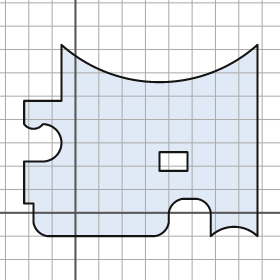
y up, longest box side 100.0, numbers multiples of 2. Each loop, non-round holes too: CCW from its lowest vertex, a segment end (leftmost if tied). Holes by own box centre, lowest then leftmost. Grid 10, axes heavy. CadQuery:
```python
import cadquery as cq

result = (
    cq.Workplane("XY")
    .moveTo(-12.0, -10.0)
    .lineTo(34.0, -10.0)
    .threePointArc((38.0, -8.0), (40.0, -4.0))
    .lineTo(40.0, 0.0)
    .threePointArc((42.0, 4.0), (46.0, 6.0))
    .lineTo(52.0, 6.0)
    .threePointArc((56.0, 4.0), (58.0, 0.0))
    .lineTo(58.0, -10.0)
    .threePointArc((68.0, -6.0), (78.0, -10.0))
    .lineTo(78.0, 72.0)
    .threePointArc((36.0, 56.0), (-6.0, 72.0))
    .lineTo(-6.0, 48.0)
    .lineTo(-22.0, 48.0)
    .lineTo(-22.0, 38.0)
    .threePointArc((-18.0, 36.0), (-14.0, 38.0))
    .threePointArc((-6.0, 30.0), (-14.0, 22.0))
    .lineTo(-22.0, 22.0)
    .lineTo(-22.0, 4.0)
    .lineTo(-18.0, 4.0)
    .lineTo(-18.0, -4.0)
    .threePointArc((-16.0, -8.0), (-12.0, -10.0))
    .close()
    .moveTo(36.0, 18.0)
    .lineTo(48.0, 18.0)
    .lineTo(48.0, 26.0)
    .lineTo(36.0, 26.0)
    .close()
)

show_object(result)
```